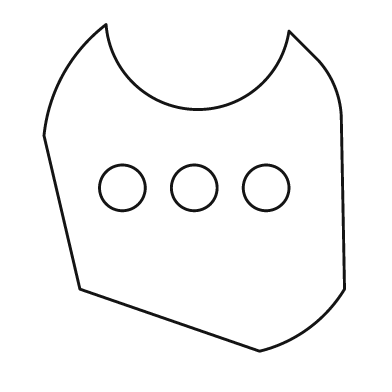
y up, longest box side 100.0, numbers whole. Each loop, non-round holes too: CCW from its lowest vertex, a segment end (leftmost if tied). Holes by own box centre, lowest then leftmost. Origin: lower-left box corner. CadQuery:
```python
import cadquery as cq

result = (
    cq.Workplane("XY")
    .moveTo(66.0, 0.0)
    .threePointArc((81.0, 7.0), (92.0, 19.0))
    .lineTo(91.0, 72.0)
    .threePointArc((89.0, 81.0), (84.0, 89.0))
    .lineTo(75.0, 98.0)
    .threePointArc((46.0, 74.0), (19.0, 100.0))
    .threePointArc((6.0, 85.0), (0.0, 66.0))
    .lineTo(11.0, 19.0)
    .close()
    .moveTo(24.0, 50.0)
    .circle(7.0)
    .moveTo(46.0, 50.0)
    .circle(7.0)
    .moveTo(68.0, 50.0)
    .circle(7.0)
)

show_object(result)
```